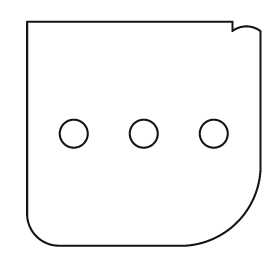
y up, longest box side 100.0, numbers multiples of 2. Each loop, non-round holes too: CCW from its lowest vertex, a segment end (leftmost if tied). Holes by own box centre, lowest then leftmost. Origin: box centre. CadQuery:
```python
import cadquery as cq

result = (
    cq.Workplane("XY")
    .moveTo(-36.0, -48.0)
    .lineTo(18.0, -48.0)
    .threePointArc((40.0, -38.0), (50.0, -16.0))
    .lineTo(50.0, 44.0)
    .threePointArc((44.0, 46.0), (38.0, 44.0))
    .lineTo(38.0, 48.0)
    .lineTo(-50.0, 48.0)
    .lineTo(-50.0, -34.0)
    .threePointArc((-46.0, -44.0), (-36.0, -48.0))
    .close()
    .moveTo(-30.0, 0.0)
    .circle(6.0)
    .moveTo(0.0, 0.0)
    .circle(6.0)
    .moveTo(30.0, 0.0)
    .circle(6.0)
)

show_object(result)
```